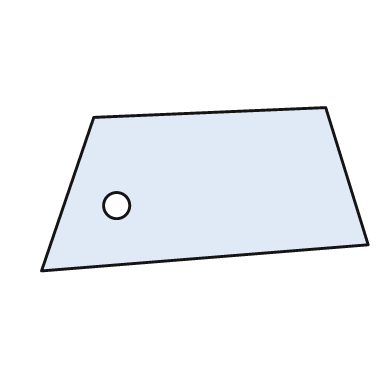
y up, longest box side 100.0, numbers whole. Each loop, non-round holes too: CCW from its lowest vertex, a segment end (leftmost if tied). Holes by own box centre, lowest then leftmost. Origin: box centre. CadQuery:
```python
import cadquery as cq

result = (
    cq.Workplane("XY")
    .moveTo(-50.0, -25.0)
    .lineTo(50.0, -17.0)
    .lineTo(37.0, 25.0)
    .lineTo(-34.0, 22.0)
    .close()
    .moveTo(-27.0, -5.0)
    .circle(4.0)
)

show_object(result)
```